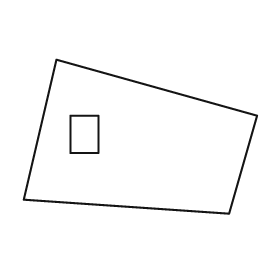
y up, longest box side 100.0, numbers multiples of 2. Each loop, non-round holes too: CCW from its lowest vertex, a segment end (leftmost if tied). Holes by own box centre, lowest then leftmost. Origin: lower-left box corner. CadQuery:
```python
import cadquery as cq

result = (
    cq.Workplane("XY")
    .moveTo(88.0, 0.0)
    .lineTo(100.0, 42.0)
    .lineTo(14.0, 66.0)
    .lineTo(0.0, 6.0)
    .close()
    .moveTo(20.0, 26.0)
    .lineTo(32.0, 26.0)
    .lineTo(32.0, 42.0)
    .lineTo(20.0, 42.0)
    .close()
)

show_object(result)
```